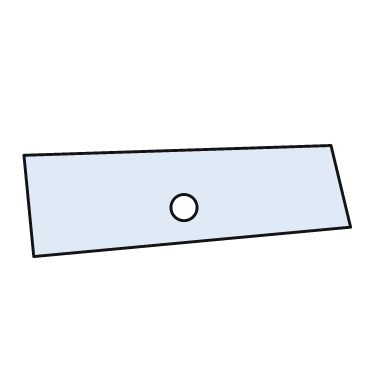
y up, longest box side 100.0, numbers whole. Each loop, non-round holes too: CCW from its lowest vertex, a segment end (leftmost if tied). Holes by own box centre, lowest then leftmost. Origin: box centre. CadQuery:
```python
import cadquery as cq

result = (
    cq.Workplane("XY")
    .moveTo(-47.0, -17.0)
    .lineTo(50.0, -8.0)
    .lineTo(44.0, 17.0)
    .lineTo(-50.0, 14.0)
    .close()
    .moveTo(-1.0, -2.0)
    .circle(4.0)
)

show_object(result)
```